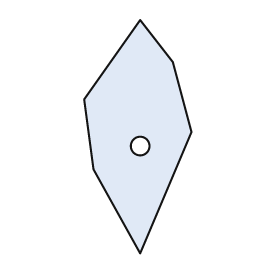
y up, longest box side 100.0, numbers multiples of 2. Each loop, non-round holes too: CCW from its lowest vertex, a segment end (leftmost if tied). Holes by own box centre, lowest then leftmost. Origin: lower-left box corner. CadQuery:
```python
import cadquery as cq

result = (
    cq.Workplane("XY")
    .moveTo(24.0, 0.0)
    .lineTo(46.0, 52.0)
    .lineTo(38.0, 82.0)
    .lineTo(24.0, 100.0)
    .lineTo(0.0, 66.0)
    .lineTo(4.0, 36.0)
    .close()
    .moveTo(24.0, 46.0)
    .circle(4.0)
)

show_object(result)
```